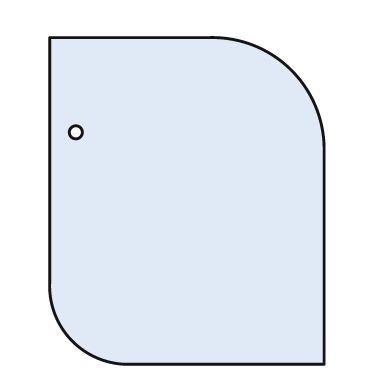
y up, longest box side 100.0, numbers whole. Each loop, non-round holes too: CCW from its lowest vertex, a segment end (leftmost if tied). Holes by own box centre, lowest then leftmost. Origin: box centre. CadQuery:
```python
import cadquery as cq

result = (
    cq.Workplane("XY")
    .moveTo(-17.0, -50.0)
    .lineTo(42.0, -50.0)
    .lineTo(42.0, 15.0)
    .threePointArc((32.0, 40.0), (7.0, 50.0))
    .lineTo(-42.0, 50.0)
    .lineTo(-42.0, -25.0)
    .threePointArc((-35.0, -43.0), (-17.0, -50.0))
    .close()
    .moveTo(-34.0, 21.0)
    .circle(2.0)
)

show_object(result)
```